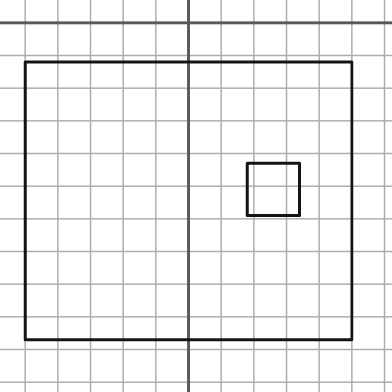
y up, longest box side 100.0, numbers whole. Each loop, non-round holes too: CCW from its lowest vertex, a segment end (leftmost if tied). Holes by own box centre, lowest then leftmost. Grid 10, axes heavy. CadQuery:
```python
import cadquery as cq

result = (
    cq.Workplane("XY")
    .moveTo(-50.0, -97.0)
    .lineTo(50.0, -97.0)
    .lineTo(50.0, -12.0)
    .lineTo(-50.0, -12.0)
    .close()
    .moveTo(18.0, -59.0)
    .lineTo(34.0, -59.0)
    .lineTo(34.0, -43.0)
    .lineTo(18.0, -43.0)
    .close()
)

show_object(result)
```